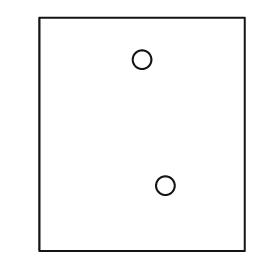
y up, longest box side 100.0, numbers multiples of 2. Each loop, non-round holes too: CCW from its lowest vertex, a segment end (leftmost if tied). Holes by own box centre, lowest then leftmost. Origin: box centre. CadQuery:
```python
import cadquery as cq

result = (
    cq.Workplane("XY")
    .moveTo(-44.0, -50.0)
    .lineTo(44.0, -50.0)
    .lineTo(44.0, 50.0)
    .lineTo(-44.0, 50.0)
    .close()
    .moveTo(10.0, -22.0)
    .circle(4.0)
    .moveTo(0.0, 32.0)
    .circle(4.0)
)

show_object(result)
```